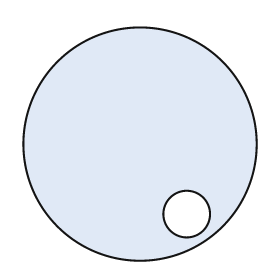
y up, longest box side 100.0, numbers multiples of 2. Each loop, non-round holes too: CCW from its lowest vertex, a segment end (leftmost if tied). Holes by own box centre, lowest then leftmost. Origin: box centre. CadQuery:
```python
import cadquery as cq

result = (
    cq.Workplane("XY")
    .moveTo(0.0, 0.0)
    .circle(50.0)
    .moveTo(20.0, -30.0)
    .circle(10.0)
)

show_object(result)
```